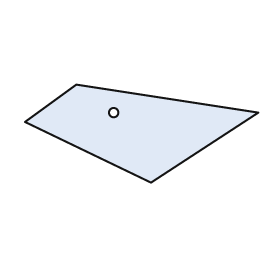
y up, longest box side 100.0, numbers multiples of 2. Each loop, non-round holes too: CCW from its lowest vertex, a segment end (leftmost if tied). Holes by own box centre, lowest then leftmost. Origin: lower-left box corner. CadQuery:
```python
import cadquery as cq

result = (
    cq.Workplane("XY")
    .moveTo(54.0, 0.0)
    .lineTo(100.0, 30.0)
    .lineTo(22.0, 42.0)
    .lineTo(0.0, 26.0)
    .close()
    .moveTo(38.0, 30.0)
    .circle(2.0)
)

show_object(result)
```